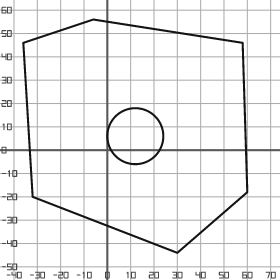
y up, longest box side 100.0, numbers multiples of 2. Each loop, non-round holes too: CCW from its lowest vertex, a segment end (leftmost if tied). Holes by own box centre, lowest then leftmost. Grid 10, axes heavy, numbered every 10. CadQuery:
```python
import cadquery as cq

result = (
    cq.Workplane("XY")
    .moveTo(30.0, -44.0)
    .lineTo(60.0, -18.0)
    .lineTo(58.0, 46.0)
    .lineTo(-6.0, 56.0)
    .lineTo(-36.0, 46.0)
    .lineTo(-32.0, -20.0)
    .close()
    .moveTo(12.0, 6.0)
    .circle(12.0)
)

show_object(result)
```